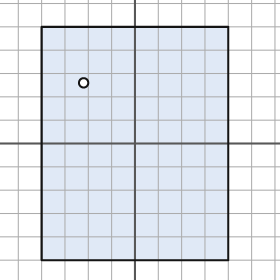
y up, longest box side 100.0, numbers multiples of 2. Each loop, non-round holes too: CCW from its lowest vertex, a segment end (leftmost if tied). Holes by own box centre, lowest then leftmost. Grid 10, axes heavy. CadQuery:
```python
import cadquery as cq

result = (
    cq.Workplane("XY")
    .moveTo(-40.0, -50.0)
    .lineTo(40.0, -50.0)
    .lineTo(40.0, 50.0)
    .lineTo(-40.0, 50.0)
    .close()
    .moveTo(-22.0, 26.0)
    .circle(2.0)
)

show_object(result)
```